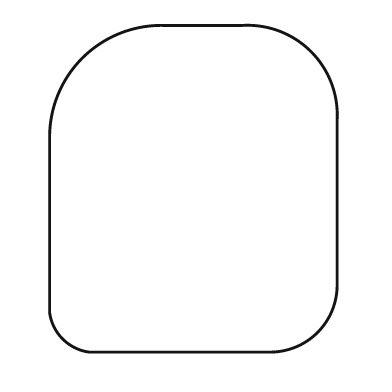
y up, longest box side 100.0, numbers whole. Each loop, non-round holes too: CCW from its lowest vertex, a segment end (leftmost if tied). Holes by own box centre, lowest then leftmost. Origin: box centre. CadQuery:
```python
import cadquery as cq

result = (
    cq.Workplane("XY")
    .moveTo(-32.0, -50.0)
    .lineTo(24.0, -50.0)
    .threePointArc((38.0, -44.0), (44.0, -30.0))
    .lineTo(44.0, 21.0)
    .threePointArc((36.0, 42.0), (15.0, 50.0))
    .lineTo(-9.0, 50.0)
    .threePointArc((-34.0, 40.0), (-44.0, 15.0))
    .lineTo(-44.0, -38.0)
    .threePointArc((-40.0, -46.0), (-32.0, -50.0))
    .close()
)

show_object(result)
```